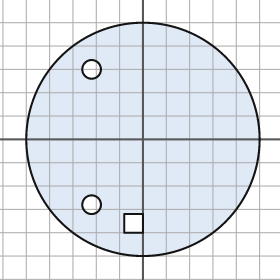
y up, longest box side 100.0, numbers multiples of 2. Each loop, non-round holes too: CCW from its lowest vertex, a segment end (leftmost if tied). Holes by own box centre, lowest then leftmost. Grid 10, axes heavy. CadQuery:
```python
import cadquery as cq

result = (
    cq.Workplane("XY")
    .moveTo(0.0, 0.0)
    .circle(50.0)
    .moveTo(-8.0, -40.0)
    .lineTo(0.0, -40.0)
    .lineTo(0.0, -32.0)
    .lineTo(-8.0, -32.0)
    .close()
    .moveTo(-22.0, -28.0)
    .circle(4.0)
    .moveTo(-22.0, 30.0)
    .circle(4.0)
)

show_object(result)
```